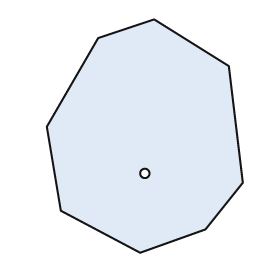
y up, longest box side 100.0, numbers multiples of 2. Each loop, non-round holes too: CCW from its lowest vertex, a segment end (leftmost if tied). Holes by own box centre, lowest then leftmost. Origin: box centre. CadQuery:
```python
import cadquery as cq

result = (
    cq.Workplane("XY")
    .moveTo(-2.0, -50.0)
    .lineTo(26.0, -40.0)
    .lineTo(42.0, -20.0)
    .lineTo(36.0, 30.0)
    .lineTo(4.0, 50.0)
    .lineTo(-20.0, 42.0)
    .lineTo(-42.0, 4.0)
    .lineTo(-36.0, -32.0)
    .close()
    .moveTo(0.0, -16.0)
    .circle(2.0)
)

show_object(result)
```